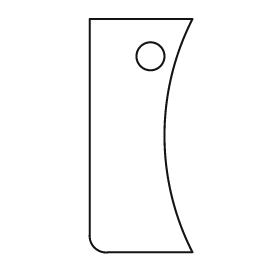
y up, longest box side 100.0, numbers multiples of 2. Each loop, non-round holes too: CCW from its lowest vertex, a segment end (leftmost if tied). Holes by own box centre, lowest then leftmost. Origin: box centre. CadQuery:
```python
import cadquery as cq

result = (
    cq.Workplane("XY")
    .moveTo(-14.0, -50.0)
    .lineTo(22.0, -50.0)
    .threePointArc((10.0, 0.0), (22.0, 50.0))
    .lineTo(-22.0, 50.0)
    .lineTo(-22.0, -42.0)
    .threePointArc((-20.0, -48.0), (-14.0, -50.0))
    .close()
    .moveTo(4.0, 34.0)
    .circle(6.0)
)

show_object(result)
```